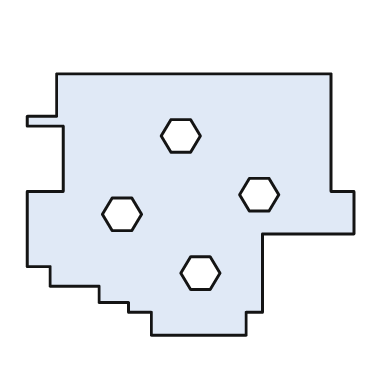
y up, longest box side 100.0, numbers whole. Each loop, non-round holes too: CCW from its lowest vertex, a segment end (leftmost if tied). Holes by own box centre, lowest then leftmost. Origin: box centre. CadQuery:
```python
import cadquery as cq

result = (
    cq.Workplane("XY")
    .moveTo(-12.0, -40.0)
    .lineTo(17.0, -40.0)
    .lineTo(17.0, -33.0)
    .lineTo(22.0, -33.0)
    .lineTo(22.0, -9.0)
    .lineTo(50.0, -9.0)
    .lineTo(50.0, 4.0)
    .lineTo(43.0, 4.0)
    .lineTo(43.0, 40.0)
    .lineTo(-41.0, 40.0)
    .lineTo(-41.0, 27.0)
    .lineTo(-50.0, 27.0)
    .lineTo(-50.0, 24.0)
    .lineTo(-39.0, 24.0)
    .lineTo(-39.0, 4.0)
    .lineTo(-50.0, 4.0)
    .lineTo(-50.0, -19.0)
    .lineTo(-43.0, -19.0)
    .lineTo(-43.0, -25.0)
    .lineTo(-28.0, -25.0)
    .lineTo(-28.0, -30.0)
    .lineTo(-19.0, -30.0)
    .lineTo(-19.0, -33.0)
    .lineTo(-12.0, -33.0)
    .close()
    .moveTo(0.0, -26.0)
    .lineTo(6.0, -26.0)
    .lineTo(9.0, -21.0)
    .lineTo(6.0, -16.0)
    .lineTo(0.0, -16.0)
    .lineTo(-3.0, -21.0)
    .close()
    .moveTo(-24.0, -8.0)
    .lineTo(-18.0, -8.0)
    .lineTo(-15.0, -3.0)
    .lineTo(-18.0, 2.0)
    .lineTo(-24.0, 2.0)
    .lineTo(-27.0, -3.0)
    .close()
    .moveTo(18.0, -2.0)
    .lineTo(24.0, -2.0)
    .lineTo(27.0, 3.0)
    .lineTo(24.0, 8.0)
    .lineTo(18.0, 8.0)
    .lineTo(15.0, 3.0)
    .close()
    .moveTo(-6.0, 16.0)
    .lineTo(0.0, 16.0)
    .lineTo(3.0, 21.0)
    .lineTo(0.0, 26.0)
    .lineTo(-6.0, 26.0)
    .lineTo(-9.0, 21.0)
    .close()
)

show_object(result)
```